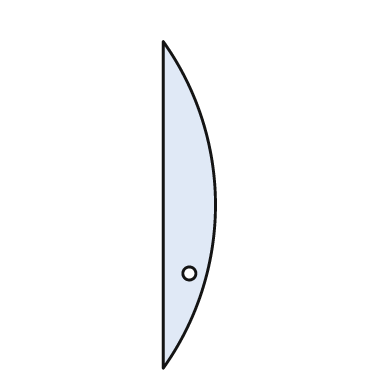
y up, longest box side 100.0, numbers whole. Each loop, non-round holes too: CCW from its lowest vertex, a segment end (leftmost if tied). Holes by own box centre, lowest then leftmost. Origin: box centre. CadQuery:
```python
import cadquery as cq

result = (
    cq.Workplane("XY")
    .moveTo(-8.0, -50.0)
    .threePointArc((8.0, 0.0), (-8.0, 50.0))
    .close()
    .moveTo(0.0, -21.0)
    .circle(2.0)
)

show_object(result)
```